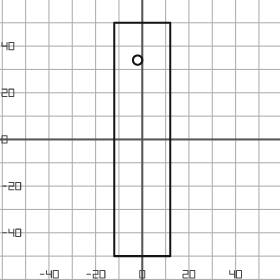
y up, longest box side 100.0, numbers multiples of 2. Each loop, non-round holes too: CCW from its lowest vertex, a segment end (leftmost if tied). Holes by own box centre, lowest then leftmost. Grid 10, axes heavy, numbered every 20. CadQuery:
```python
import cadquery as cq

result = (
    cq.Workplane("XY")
    .moveTo(-12.0, -50.0)
    .lineTo(12.0, -50.0)
    .lineTo(12.0, 50.0)
    .lineTo(-12.0, 50.0)
    .close()
    .moveTo(-2.0, 34.0)
    .circle(2.0)
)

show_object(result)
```